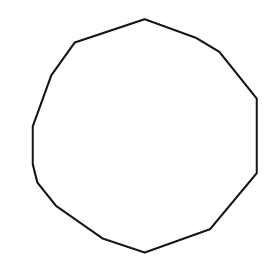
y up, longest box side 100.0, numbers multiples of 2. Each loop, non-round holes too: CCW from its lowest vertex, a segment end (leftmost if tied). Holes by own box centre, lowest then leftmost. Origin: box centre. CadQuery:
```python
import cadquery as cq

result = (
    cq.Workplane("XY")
    .moveTo(0.0, -50.0)
    .lineTo(28.0, -40.0)
    .lineTo(48.0, -16.0)
    .lineTo(48.0, 16.0)
    .lineTo(32.0, 36.0)
    .lineTo(22.0, 42.0)
    .lineTo(0.0, 50.0)
    .lineTo(-30.0, 40.0)
    .lineTo(-40.0, 26.0)
    .lineTo(-48.0, 4.0)
    .lineTo(-48.0, -12.0)
    .lineTo(-46.0, -20.0)
    .lineTo(-38.0, -30.0)
    .lineTo(-18.0, -44.0)
    .close()
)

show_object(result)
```